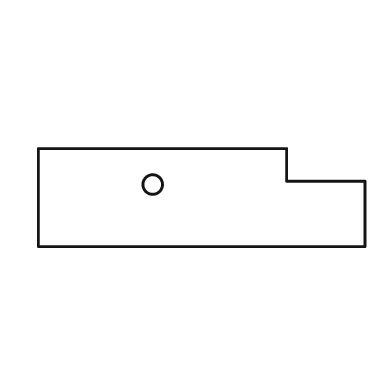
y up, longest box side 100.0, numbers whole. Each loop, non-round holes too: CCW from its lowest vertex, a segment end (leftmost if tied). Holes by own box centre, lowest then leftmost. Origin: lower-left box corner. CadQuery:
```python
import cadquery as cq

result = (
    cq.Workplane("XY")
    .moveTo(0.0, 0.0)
    .lineTo(100.0, 0.0)
    .lineTo(100.0, 20.0)
    .lineTo(76.0, 20.0)
    .lineTo(76.0, 30.0)
    .lineTo(0.0, 30.0)
    .close()
    .moveTo(35.0, 19.0)
    .circle(3.0)
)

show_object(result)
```